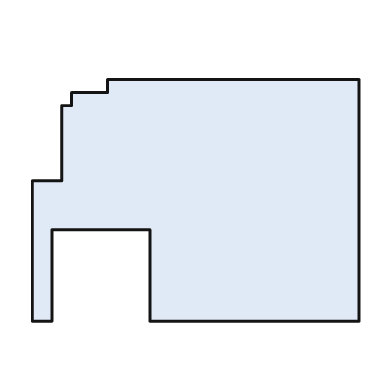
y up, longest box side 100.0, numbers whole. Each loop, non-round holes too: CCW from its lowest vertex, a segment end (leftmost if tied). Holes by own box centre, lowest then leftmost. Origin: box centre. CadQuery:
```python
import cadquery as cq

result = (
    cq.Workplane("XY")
    .moveTo(-50.0, -37.0)
    .lineTo(-44.0, -37.0)
    .lineTo(-44.0, -9.0)
    .lineTo(-14.0, -9.0)
    .lineTo(-14.0, -37.0)
    .lineTo(50.0, -37.0)
    .lineTo(50.0, 37.0)
    .lineTo(-27.0, 37.0)
    .lineTo(-27.0, 33.0)
    .lineTo(-38.0, 33.0)
    .lineTo(-38.0, 29.0)
    .lineTo(-41.0, 29.0)
    .lineTo(-41.0, 6.0)
    .lineTo(-50.0, 6.0)
    .close()
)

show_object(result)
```